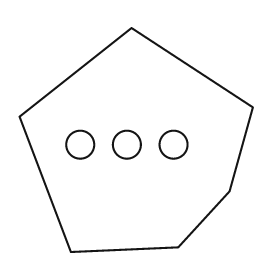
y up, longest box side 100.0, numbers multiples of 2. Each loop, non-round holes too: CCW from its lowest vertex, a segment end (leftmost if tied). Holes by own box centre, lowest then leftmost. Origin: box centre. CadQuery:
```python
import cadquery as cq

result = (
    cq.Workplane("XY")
    .moveTo(-28.0, -48.0)
    .lineTo(18.0, -46.0)
    .lineTo(40.0, -22.0)
    .lineTo(50.0, 14.0)
    .lineTo(-2.0, 48.0)
    .lineTo(-50.0, 10.0)
    .close()
    .moveTo(-24.0, -2.0)
    .circle(6.0)
    .moveTo(-4.0, -2.0)
    .circle(6.0)
    .moveTo(16.0, -2.0)
    .circle(6.0)
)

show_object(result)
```